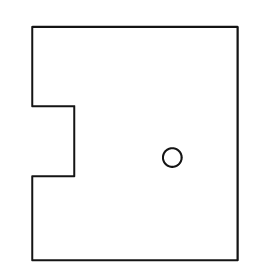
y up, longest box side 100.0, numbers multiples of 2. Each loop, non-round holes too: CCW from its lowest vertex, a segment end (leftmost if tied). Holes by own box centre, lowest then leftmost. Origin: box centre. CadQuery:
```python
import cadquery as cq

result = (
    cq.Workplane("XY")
    .moveTo(-44.0, -50.0)
    .lineTo(44.0, -50.0)
    .lineTo(44.0, 50.0)
    .lineTo(-44.0, 50.0)
    .lineTo(-44.0, 16.0)
    .lineTo(-26.0, 16.0)
    .lineTo(-26.0, -14.0)
    .lineTo(-44.0, -14.0)
    .close()
    .moveTo(16.0, -6.0)
    .circle(4.0)
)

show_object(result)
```